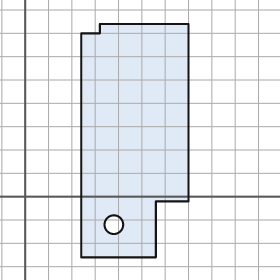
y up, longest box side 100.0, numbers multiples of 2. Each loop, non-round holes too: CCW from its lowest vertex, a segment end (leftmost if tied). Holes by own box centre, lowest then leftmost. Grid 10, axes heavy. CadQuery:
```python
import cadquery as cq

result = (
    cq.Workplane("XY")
    .moveTo(24.0, -26.0)
    .lineTo(56.0, -26.0)
    .lineTo(56.0, -2.0)
    .lineTo(70.0, -2.0)
    .lineTo(70.0, 74.0)
    .lineTo(32.0, 74.0)
    .lineTo(32.0, 70.0)
    .lineTo(24.0, 70.0)
    .close()
    .moveTo(38.0, -12.0)
    .circle(4.0)
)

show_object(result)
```